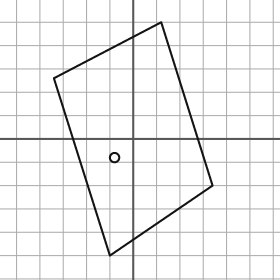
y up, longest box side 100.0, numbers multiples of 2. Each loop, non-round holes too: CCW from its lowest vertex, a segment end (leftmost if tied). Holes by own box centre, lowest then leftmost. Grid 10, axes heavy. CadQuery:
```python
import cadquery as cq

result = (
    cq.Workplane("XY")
    .moveTo(-10.0, -50.0)
    .lineTo(34.0, -20.0)
    .lineTo(12.0, 50.0)
    .lineTo(-34.0, 26.0)
    .close()
    .moveTo(-8.0, -8.0)
    .circle(2.0)
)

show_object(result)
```